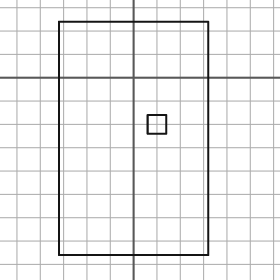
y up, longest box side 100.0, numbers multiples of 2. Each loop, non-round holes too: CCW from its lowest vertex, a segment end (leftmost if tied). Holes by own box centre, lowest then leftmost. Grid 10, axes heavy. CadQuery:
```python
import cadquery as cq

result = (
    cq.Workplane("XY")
    .moveTo(-32.0, -76.0)
    .lineTo(32.0, -76.0)
    .lineTo(32.0, 24.0)
    .lineTo(-32.0, 24.0)
    .close()
    .moveTo(6.0, -24.0)
    .lineTo(14.0, -24.0)
    .lineTo(14.0, -16.0)
    .lineTo(6.0, -16.0)
    .close()
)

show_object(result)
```